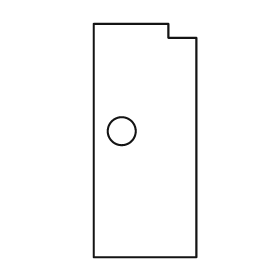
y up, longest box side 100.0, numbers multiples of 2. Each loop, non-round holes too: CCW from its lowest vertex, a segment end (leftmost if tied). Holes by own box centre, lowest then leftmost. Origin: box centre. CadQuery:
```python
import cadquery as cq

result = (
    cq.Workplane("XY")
    .moveTo(-22.0, -50.0)
    .lineTo(22.0, -50.0)
    .lineTo(22.0, 44.0)
    .lineTo(10.0, 44.0)
    .lineTo(10.0, 50.0)
    .lineTo(-22.0, 50.0)
    .close()
    .moveTo(-10.0, 4.0)
    .circle(6.0)
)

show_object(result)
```